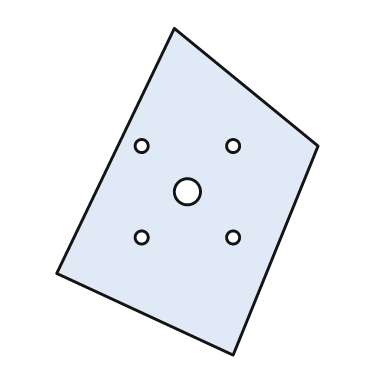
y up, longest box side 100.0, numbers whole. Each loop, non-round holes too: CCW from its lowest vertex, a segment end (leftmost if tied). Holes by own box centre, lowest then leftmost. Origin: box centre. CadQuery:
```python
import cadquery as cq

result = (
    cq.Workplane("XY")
    .moveTo(14.0, -50.0)
    .lineTo(40.0, 14.0)
    .lineTo(-4.0, 50.0)
    .lineTo(-40.0, -25.0)
    .close()
    .moveTo(-14.0, -14.0)
    .circle(2.0)
    .moveTo(14.0, -14.0)
    .circle(2.0)
    .moveTo(0.0, 0.0)
    .circle(4.0)
    .moveTo(-14.0, 14.0)
    .circle(2.0)
    .moveTo(14.0, 14.0)
    .circle(2.0)
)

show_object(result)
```